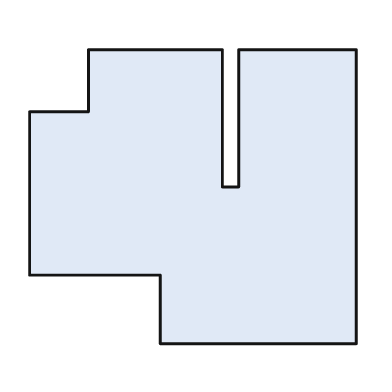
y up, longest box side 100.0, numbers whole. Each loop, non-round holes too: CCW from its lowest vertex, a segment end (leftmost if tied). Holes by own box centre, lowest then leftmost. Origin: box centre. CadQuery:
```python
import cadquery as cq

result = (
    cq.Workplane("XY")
    .moveTo(-10.0, -45.0)
    .lineTo(50.0, -45.0)
    .lineTo(50.0, 45.0)
    .lineTo(14.0, 45.0)
    .lineTo(14.0, 3.0)
    .lineTo(9.0, 3.0)
    .lineTo(9.0, 45.0)
    .lineTo(-32.0, 45.0)
    .lineTo(-32.0, 26.0)
    .lineTo(-50.0, 26.0)
    .lineTo(-50.0, -24.0)
    .lineTo(-10.0, -24.0)
    .close()
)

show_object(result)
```